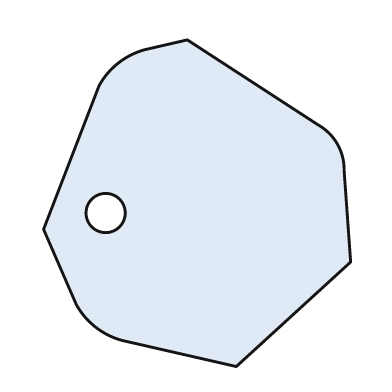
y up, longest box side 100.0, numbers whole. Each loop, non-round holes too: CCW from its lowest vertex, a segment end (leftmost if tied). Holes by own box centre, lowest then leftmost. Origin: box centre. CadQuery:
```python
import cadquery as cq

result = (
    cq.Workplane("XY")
    .moveTo(12.0, -50.0)
    .lineTo(47.0, -18.0)
    .lineTo(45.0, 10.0)
    .threePointArc((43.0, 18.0), (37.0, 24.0))
    .lineTo(-3.0, 50.0)
    .lineTo(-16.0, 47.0)
    .threePointArc((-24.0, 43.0), (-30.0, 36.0))
    .lineTo(-47.0, -8.0)
    .lineTo(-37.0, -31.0)
    .threePointArc((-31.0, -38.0), (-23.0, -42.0))
    .close()
    .moveTo(-28.0, -3.0)
    .circle(6.0)
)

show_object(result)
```